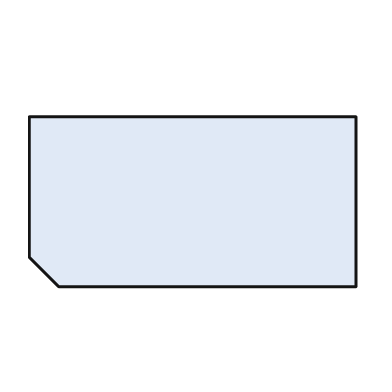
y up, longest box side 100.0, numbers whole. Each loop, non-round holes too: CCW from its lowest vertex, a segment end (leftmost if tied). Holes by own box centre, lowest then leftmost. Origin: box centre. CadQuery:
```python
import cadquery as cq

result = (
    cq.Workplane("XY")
    .moveTo(-41.0, -26.0)
    .lineTo(50.0, -26.0)
    .lineTo(50.0, 26.0)
    .lineTo(-50.0, 26.0)
    .lineTo(-50.0, -17.0)
    .close()
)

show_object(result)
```